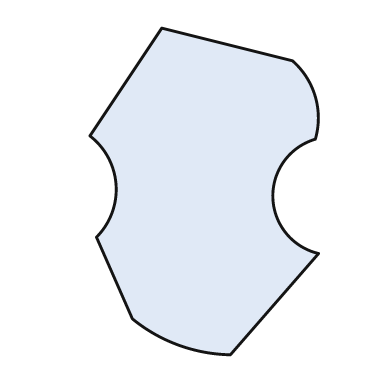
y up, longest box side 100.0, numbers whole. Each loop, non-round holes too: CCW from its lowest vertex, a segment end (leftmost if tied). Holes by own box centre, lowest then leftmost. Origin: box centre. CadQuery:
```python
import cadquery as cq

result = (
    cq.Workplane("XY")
    .moveTo(8.0, -50.0)
    .lineTo(35.0, -19.0)
    .threePointArc((21.0, -2.0), (34.0, 16.0))
    .threePointArc((34.0, 29.0), (27.0, 40.0))
    .lineTo(-13.0, 50.0)
    .lineTo(-35.0, 17.0)
    .threePointArc((-27.0, 2.0), (-33.0, -14.0))
    .lineTo(-22.0, -39.0)
    .threePointArc((-8.0, -47.0), (8.0, -50.0))
    .close()
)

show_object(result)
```